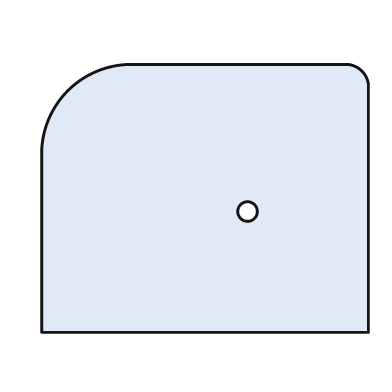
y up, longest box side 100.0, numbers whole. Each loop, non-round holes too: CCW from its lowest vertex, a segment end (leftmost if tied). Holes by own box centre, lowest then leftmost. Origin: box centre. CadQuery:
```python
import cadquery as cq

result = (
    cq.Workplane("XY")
    .moveTo(-50.0, -41.0)
    .lineTo(50.0, -41.0)
    .lineTo(50.0, 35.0)
    .threePointArc((48.0, 39.0), (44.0, 41.0))
    .lineTo(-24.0, 41.0)
    .threePointArc((-42.0, 33.0), (-50.0, 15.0))
    .close()
    .moveTo(13.0, -4.0)
    .circle(3.0)
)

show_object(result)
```